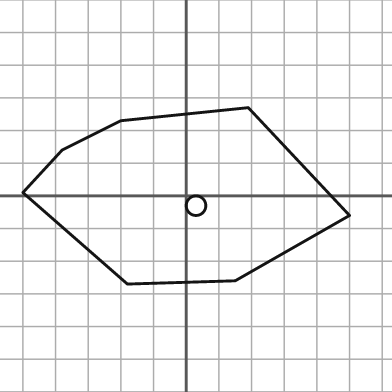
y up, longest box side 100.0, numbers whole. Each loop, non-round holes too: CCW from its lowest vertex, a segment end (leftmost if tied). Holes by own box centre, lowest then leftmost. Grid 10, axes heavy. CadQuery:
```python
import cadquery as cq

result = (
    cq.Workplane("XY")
    .moveTo(-18.0, -27.0)
    .lineTo(15.0, -26.0)
    .lineTo(50.0, -6.0)
    .lineTo(19.0, 27.0)
    .lineTo(-20.0, 23.0)
    .lineTo(-38.0, 14.0)
    .lineTo(-50.0, 1.0)
    .close()
    .moveTo(3.0, -3.0)
    .circle(3.0)
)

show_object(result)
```